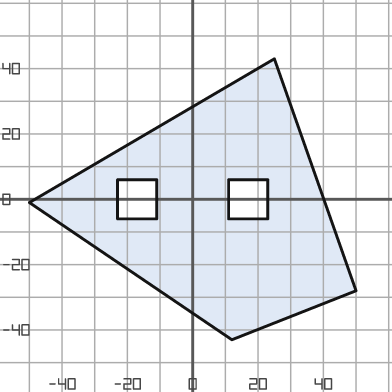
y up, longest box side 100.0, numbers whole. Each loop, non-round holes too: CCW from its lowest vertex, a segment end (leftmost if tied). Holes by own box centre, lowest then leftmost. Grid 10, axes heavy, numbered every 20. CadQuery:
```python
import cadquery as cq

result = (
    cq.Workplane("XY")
    .moveTo(12.0, -43.0)
    .lineTo(50.0, -28.0)
    .lineTo(25.0, 43.0)
    .lineTo(-50.0, -1.0)
    .close()
    .moveTo(-23.0, -6.0)
    .lineTo(-11.0, -6.0)
    .lineTo(-11.0, 6.0)
    .lineTo(-23.0, 6.0)
    .close()
    .moveTo(11.0, -6.0)
    .lineTo(23.0, -6.0)
    .lineTo(23.0, 6.0)
    .lineTo(11.0, 6.0)
    .close()
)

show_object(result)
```